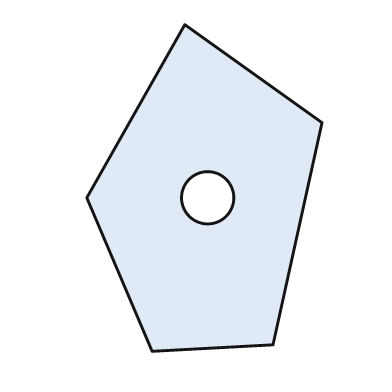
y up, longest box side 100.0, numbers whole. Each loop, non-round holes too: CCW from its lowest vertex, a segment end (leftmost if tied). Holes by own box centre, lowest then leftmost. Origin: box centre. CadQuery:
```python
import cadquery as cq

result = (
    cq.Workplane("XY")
    .moveTo(-16.0, -50.0)
    .lineTo(21.0, -48.0)
    .lineTo(36.0, 20.0)
    .lineTo(-6.0, 50.0)
    .lineTo(-36.0, -3.0)
    .close()
    .moveTo(1.0, -3.0)
    .circle(8.0)
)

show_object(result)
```